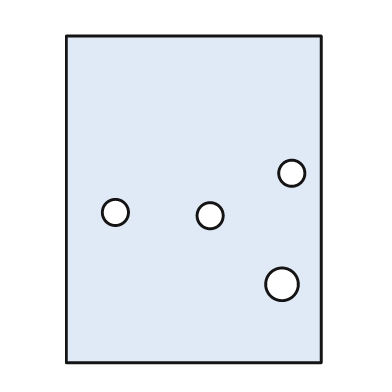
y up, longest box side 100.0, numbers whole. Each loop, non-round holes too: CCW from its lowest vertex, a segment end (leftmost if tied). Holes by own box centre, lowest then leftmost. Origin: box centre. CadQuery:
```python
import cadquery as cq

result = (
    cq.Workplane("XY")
    .moveTo(-39.0, -50.0)
    .lineTo(39.0, -50.0)
    .lineTo(39.0, 50.0)
    .lineTo(-39.0, 50.0)
    .close()
    .moveTo(27.0, -26.0)
    .circle(5.0)
    .moveTo(5.0, -5.0)
    .circle(4.0)
    .moveTo(-24.0, -4.0)
    .circle(4.0)
    .moveTo(30.0, 8.0)
    .circle(4.0)
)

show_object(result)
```